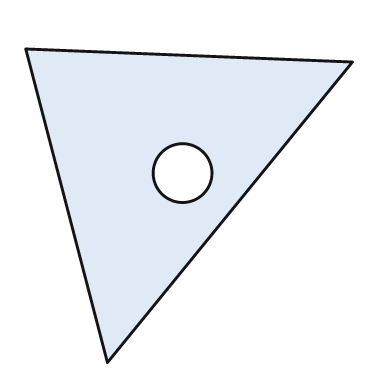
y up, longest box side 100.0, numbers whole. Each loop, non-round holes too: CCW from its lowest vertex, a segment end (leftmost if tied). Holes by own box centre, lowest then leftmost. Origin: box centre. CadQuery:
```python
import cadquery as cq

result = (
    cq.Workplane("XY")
    .moveTo(-25.0, -48.0)
    .lineTo(50.0, 44.0)
    .lineTo(-50.0, 48.0)
    .close()
    .moveTo(-2.0, 10.0)
    .circle(9.0)
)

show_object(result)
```